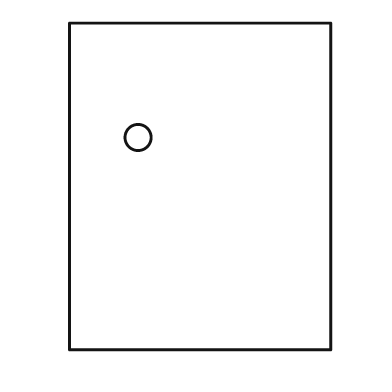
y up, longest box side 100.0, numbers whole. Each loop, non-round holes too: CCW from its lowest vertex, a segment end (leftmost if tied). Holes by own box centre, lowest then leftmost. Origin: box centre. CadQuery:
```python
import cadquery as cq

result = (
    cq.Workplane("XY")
    .moveTo(-40.0, -50.0)
    .lineTo(40.0, -50.0)
    .lineTo(40.0, 50.0)
    .lineTo(-40.0, 50.0)
    .close()
    .moveTo(-19.0, 15.0)
    .circle(4.0)
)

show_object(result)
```